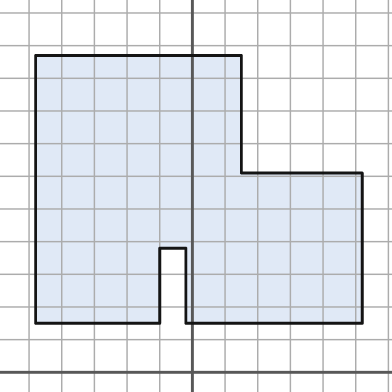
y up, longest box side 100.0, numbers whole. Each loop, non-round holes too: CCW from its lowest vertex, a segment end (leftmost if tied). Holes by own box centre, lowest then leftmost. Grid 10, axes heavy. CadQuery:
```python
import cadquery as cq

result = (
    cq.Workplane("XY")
    .moveTo(-48.0, 15.0)
    .lineTo(-10.0, 15.0)
    .lineTo(-10.0, 38.0)
    .lineTo(-2.0, 38.0)
    .lineTo(-2.0, 15.0)
    .lineTo(52.0, 15.0)
    .lineTo(52.0, 61.0)
    .lineTo(15.0, 61.0)
    .lineTo(15.0, 97.0)
    .lineTo(-48.0, 97.0)
    .close()
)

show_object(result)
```